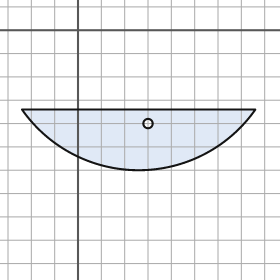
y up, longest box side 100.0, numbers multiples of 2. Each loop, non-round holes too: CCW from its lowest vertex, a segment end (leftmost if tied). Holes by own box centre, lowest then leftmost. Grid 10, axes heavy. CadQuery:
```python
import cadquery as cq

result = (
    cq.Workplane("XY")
    .moveTo(-24.0, -34.0)
    .threePointArc((26.0, -60.0), (76.0, -34.0))
    .close()
    .moveTo(30.0, -40.0)
    .circle(2.0)
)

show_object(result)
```